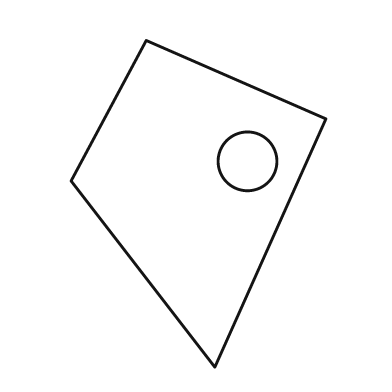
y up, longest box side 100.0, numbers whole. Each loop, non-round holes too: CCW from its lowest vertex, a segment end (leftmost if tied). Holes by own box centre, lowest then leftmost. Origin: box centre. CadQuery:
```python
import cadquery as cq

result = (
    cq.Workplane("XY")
    .moveTo(5.0, -50.0)
    .lineTo(39.0, 26.0)
    .lineTo(-16.0, 50.0)
    .lineTo(-39.0, 7.0)
    .close()
    .moveTo(15.0, 13.0)
    .circle(9.0)
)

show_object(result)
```